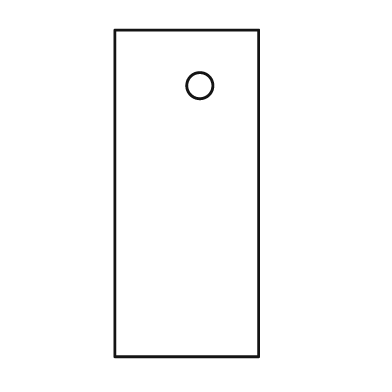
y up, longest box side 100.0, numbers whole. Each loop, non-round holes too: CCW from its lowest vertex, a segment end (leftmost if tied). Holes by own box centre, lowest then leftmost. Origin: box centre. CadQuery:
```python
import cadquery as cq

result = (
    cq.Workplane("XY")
    .moveTo(-22.0, -50.0)
    .lineTo(22.0, -50.0)
    .lineTo(22.0, 50.0)
    .lineTo(-22.0, 50.0)
    .close()
    .moveTo(4.0, 33.0)
    .circle(4.0)
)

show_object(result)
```